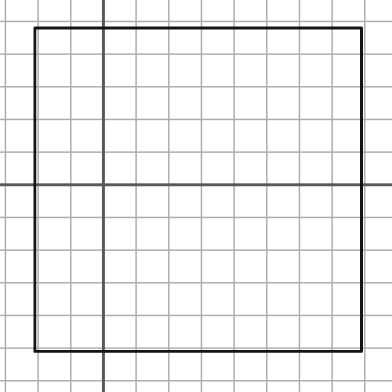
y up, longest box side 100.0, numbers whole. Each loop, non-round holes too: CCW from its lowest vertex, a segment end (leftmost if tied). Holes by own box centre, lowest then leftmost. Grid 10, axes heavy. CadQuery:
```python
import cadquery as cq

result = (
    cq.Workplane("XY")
    .moveTo(-21.0, -51.0)
    .lineTo(79.0, -51.0)
    .lineTo(79.0, 48.0)
    .lineTo(-21.0, 48.0)
    .close()
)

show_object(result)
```